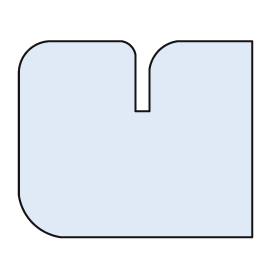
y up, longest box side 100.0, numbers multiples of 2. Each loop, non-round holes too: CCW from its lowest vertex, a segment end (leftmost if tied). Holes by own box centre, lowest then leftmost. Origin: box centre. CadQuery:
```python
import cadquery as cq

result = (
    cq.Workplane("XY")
    .moveTo(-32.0, -42.0)
    .lineTo(50.0, -42.0)
    .lineTo(50.0, 42.0)
    .lineTo(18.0, 42.0)
    .threePointArc((10.0, 38.0), (6.0, 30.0))
    .lineTo(6.0, 12.0)
    .lineTo(0.0, 12.0)
    .lineTo(0.0, 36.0)
    .threePointArc((-2.0, 40.0), (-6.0, 42.0))
    .lineTo(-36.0, 42.0)
    .threePointArc((-46.0, 38.0), (-50.0, 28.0))
    .lineTo(-50.0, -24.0)
    .threePointArc((-44.0, -36.0), (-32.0, -42.0))
    .close()
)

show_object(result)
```